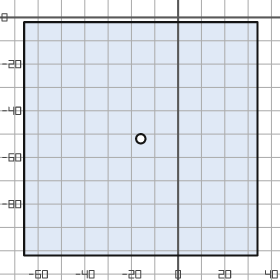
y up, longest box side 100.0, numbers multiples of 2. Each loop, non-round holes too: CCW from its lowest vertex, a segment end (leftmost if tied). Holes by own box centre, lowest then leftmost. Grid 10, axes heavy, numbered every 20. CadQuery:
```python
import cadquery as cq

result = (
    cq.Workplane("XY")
    .moveTo(-66.0, -102.0)
    .lineTo(34.0, -102.0)
    .lineTo(34.0, -2.0)
    .lineTo(-66.0, -2.0)
    .close()
    .moveTo(-16.0, -52.0)
    .circle(2.0)
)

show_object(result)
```